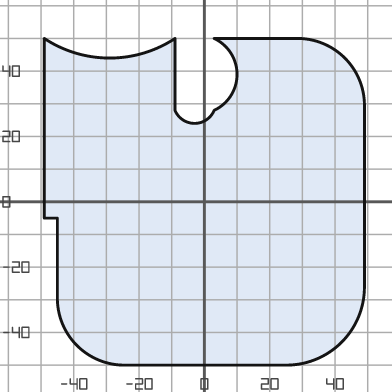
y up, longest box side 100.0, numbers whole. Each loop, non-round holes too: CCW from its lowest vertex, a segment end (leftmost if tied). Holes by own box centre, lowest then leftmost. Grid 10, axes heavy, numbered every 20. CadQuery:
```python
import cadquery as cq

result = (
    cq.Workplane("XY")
    .moveTo(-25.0, -50.0)
    .lineTo(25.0, -50.0)
    .threePointArc((42.0, -43.0), (49.0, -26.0))
    .lineTo(49.0, 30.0)
    .threePointArc((43.0, 44.0), (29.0, 50.0))
    .lineTo(3.0, 50.0)
    .threePointArc((10.0, 39.0), (3.0, 28.0))
    .threePointArc((-3.0, 24.0), (-9.0, 28.0))
    .lineTo(-9.0, 50.0)
    .threePointArc((-29.0, 44.0), (-49.0, 50.0))
    .lineTo(-49.0, -5.0)
    .lineTo(-45.0, -5.0)
    .lineTo(-45.0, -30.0)
    .threePointArc((-39.0, -44.0), (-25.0, -50.0))
    .close()
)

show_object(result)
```